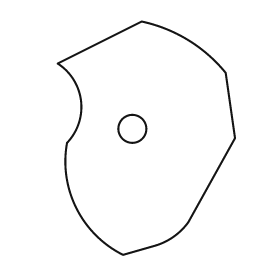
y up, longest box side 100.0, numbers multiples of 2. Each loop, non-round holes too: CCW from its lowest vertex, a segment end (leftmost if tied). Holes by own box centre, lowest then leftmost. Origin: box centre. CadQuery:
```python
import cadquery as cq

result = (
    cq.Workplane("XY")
    .moveTo(-10.0, -50.0)
    .lineTo(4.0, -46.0)
    .threePointArc((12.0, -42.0), (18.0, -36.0))
    .lineTo(38.0, 0.0)
    .lineTo(34.0, 28.0)
    .threePointArc((18.0, 42.0), (-2.0, 50.0))
    .lineTo(-38.0, 32.0)
    .threePointArc((-28.0, 16.0), (-34.0, -2.0))
    .threePointArc((-30.0, -30.0), (-10.0, -50.0))
    .close()
    .moveTo(-6.0, 4.0)
    .circle(6.0)
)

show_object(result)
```